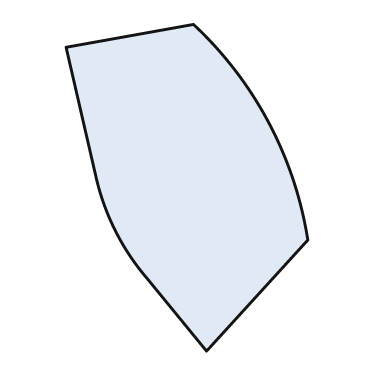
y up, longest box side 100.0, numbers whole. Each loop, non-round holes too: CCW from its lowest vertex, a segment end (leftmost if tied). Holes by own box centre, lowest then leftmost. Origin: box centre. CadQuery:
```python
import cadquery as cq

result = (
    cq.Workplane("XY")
    .moveTo(6.0, -50.0)
    .lineTo(37.0, -16.0)
    .threePointArc((25.0, 20.0), (2.0, 50.0))
    .lineTo(-37.0, 43.0)
    .lineTo(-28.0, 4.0)
    .threePointArc((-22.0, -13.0), (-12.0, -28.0))
    .close()
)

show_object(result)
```